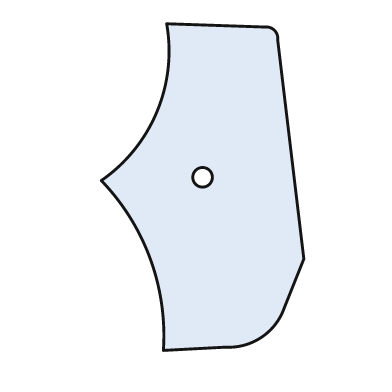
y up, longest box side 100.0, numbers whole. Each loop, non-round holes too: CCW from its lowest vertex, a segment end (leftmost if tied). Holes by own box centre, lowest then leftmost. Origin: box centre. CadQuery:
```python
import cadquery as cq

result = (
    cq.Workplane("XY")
    .moveTo(-12.0, -50.0)
    .lineTo(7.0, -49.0)
    .threePointArc((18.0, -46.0), (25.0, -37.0))
    .lineTo(31.0, -22.0)
    .lineTo(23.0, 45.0)
    .threePointArc((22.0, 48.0), (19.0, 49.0))
    .lineTo(-11.0, 50.0)
    .threePointArc((-14.0, 23.0), (-31.0, 2.0))
    .threePointArc((-16.0, -22.0), (-12.0, -50.0))
    .close()
    .moveTo(0.0, 3.0)
    .circle(3.0)
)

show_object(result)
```